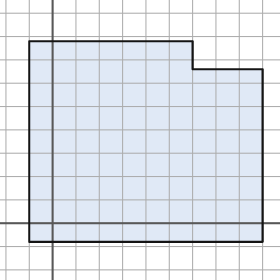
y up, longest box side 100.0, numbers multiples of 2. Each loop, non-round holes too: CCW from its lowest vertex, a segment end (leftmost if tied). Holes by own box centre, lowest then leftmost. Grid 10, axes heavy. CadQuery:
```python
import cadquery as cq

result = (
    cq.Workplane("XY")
    .moveTo(-10.0, -8.0)
    .lineTo(90.0, -8.0)
    .lineTo(90.0, 66.0)
    .lineTo(60.0, 66.0)
    .lineTo(60.0, 78.0)
    .lineTo(-10.0, 78.0)
    .close()
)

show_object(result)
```